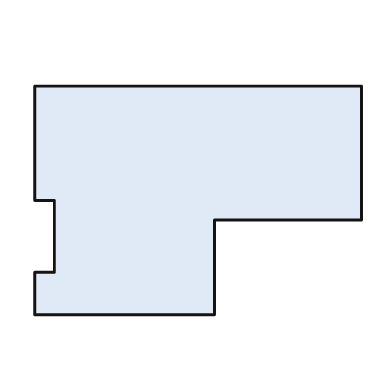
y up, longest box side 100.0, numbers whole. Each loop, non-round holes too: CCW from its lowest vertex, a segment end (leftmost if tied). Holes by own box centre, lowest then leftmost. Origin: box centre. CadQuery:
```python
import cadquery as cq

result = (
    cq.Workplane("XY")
    .moveTo(-50.0, -35.0)
    .lineTo(5.0, -35.0)
    .lineTo(5.0, -6.0)
    .lineTo(50.0, -6.0)
    .lineTo(50.0, 35.0)
    .lineTo(-50.0, 35.0)
    .lineTo(-50.0, 0.0)
    .lineTo(-44.0, 0.0)
    .lineTo(-44.0, -22.0)
    .lineTo(-50.0, -22.0)
    .close()
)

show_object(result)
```